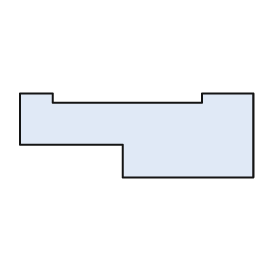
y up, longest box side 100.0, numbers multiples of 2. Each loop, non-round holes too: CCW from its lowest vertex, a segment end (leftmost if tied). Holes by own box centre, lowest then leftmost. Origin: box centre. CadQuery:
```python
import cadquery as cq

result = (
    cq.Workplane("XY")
    .moveTo(-6.0, -18.0)
    .lineTo(50.0, -18.0)
    .lineTo(50.0, 18.0)
    .lineTo(28.0, 18.0)
    .lineTo(28.0, 14.0)
    .lineTo(-36.0, 14.0)
    .lineTo(-36.0, 18.0)
    .lineTo(-50.0, 18.0)
    .lineTo(-50.0, -4.0)
    .lineTo(-6.0, -4.0)
    .close()
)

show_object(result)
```